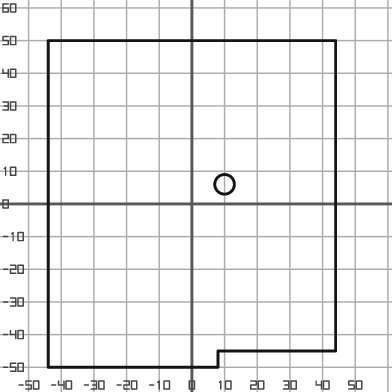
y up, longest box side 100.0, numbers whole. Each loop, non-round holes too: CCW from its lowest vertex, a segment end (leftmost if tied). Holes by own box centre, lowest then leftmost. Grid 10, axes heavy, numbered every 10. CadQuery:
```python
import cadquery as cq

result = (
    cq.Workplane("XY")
    .moveTo(-44.0, -50.0)
    .lineTo(8.0, -50.0)
    .lineTo(8.0, -45.0)
    .lineTo(44.0, -45.0)
    .lineTo(44.0, 50.0)
    .lineTo(-44.0, 50.0)
    .close()
    .moveTo(10.0, 6.0)
    .circle(3.0)
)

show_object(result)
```